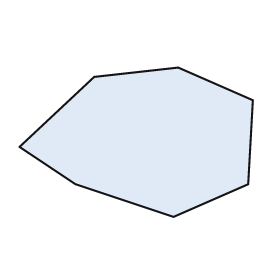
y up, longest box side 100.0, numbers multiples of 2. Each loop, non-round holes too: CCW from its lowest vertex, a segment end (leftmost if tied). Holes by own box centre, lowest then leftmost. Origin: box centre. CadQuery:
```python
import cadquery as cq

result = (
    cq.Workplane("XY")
    .moveTo(16.0, -32.0)
    .lineTo(48.0, -18.0)
    .lineTo(50.0, 18.0)
    .lineTo(18.0, 32.0)
    .lineTo(-18.0, 28.0)
    .lineTo(-50.0, -2.0)
    .lineTo(-26.0, -18.0)
    .close()
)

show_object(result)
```